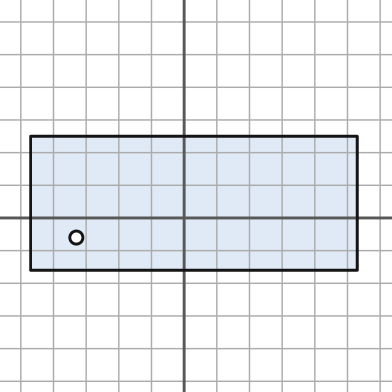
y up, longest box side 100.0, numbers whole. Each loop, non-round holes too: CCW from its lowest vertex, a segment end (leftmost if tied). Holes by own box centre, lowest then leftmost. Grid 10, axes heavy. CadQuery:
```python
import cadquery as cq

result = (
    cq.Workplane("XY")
    .moveTo(-47.0, -16.0)
    .lineTo(53.0, -16.0)
    .lineTo(53.0, 25.0)
    .lineTo(-47.0, 25.0)
    .close()
    .moveTo(-33.0, -6.0)
    .circle(2.0)
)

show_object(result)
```